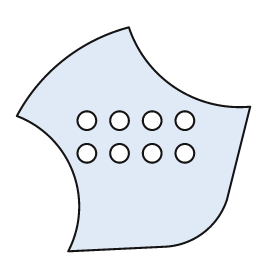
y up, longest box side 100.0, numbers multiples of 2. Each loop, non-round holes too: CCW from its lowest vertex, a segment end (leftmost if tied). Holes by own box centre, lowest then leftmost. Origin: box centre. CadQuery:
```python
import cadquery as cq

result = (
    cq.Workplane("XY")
    .moveTo(-28.0, -48.0)
    .lineTo(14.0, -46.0)
    .threePointArc((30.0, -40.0), (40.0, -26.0))
    .lineTo(50.0, 14.0)
    .threePointArc((18.0, 22.0), (-2.0, 48.0))
    .threePointArc((-30.0, 34.0), (-50.0, 10.0))
    .threePointArc((-26.0, -14.0), (-28.0, -48.0))
    .close()
    .moveTo(-20.0, -6.0)
    .circle(4.0)
    .moveTo(-6.0, -6.0)
    .circle(4.0)
    .moveTo(8.0, -6.0)
    .circle(4.0)
    .moveTo(22.0, -6.0)
    .circle(4.0)
    .moveTo(-20.0, 8.0)
    .circle(4.0)
    .moveTo(-6.0, 8.0)
    .circle(4.0)
    .moveTo(8.0, 8.0)
    .circle(4.0)
    .moveTo(22.0, 8.0)
    .circle(4.0)
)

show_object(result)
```